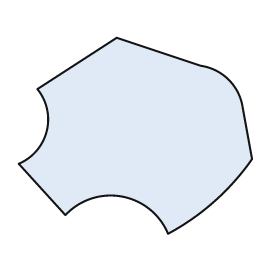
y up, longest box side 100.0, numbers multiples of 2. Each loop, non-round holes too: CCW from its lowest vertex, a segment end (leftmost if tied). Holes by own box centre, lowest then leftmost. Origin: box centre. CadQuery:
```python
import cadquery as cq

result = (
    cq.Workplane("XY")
    .moveTo(14.0, -42.0)
    .threePointArc((34.0, -28.0), (50.0, -10.0))
    .lineTo(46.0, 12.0)
    .threePointArc((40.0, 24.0), (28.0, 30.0))
    .lineTo(-8.0, 42.0)
    .lineTo(-42.0, 20.0)
    .threePointArc((-38.0, 2.0), (-50.0, -12.0))
    .lineTo(-30.0, -34.0)
    .threePointArc((-6.0, -26.0), (14.0, -42.0))
    .close()
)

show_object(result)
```